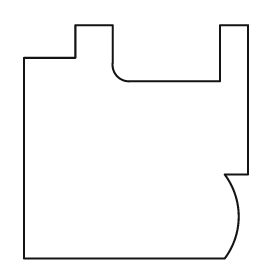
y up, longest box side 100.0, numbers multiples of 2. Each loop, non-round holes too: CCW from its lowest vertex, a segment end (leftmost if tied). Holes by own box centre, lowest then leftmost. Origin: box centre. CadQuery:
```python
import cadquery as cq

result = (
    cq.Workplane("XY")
    .moveTo(-48.0, -50.0)
    .lineTo(38.0, -50.0)
    .threePointArc((44.0, -32.0), (38.0, -14.0))
    .lineTo(48.0, -14.0)
    .lineTo(48.0, 50.0)
    .lineTo(36.0, 50.0)
    .lineTo(36.0, 26.0)
    .lineTo(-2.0, 26.0)
    .threePointArc((-8.0, 28.0), (-10.0, 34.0))
    .lineTo(-10.0, 50.0)
    .lineTo(-26.0, 50.0)
    .lineTo(-26.0, 36.0)
    .lineTo(-48.0, 36.0)
    .close()
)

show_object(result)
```